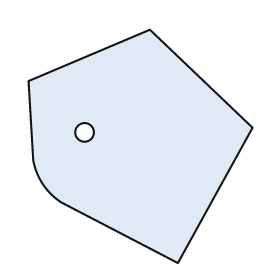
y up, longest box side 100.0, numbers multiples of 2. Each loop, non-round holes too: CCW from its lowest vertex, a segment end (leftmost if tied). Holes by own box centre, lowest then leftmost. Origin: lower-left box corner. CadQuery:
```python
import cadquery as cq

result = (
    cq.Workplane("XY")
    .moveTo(64.0, 0.0)
    .lineTo(96.0, 58.0)
    .lineTo(52.0, 100.0)
    .lineTo(0.0, 78.0)
    .lineTo(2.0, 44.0)
    .threePointArc((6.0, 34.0), (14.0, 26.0))
    .close()
    .moveTo(24.0, 56.0)
    .circle(4.0)
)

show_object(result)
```